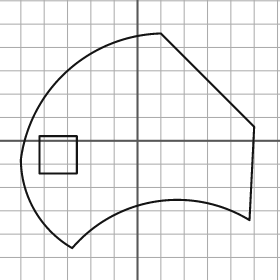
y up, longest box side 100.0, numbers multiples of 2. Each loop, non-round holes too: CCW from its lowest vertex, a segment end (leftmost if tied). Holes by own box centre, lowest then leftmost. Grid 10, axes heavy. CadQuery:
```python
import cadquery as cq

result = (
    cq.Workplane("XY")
    .moveTo(-28.0, -46.0)
    .threePointArc((8.0, -26.0), (48.0, -34.0))
    .lineTo(50.0, 6.0)
    .lineTo(10.0, 46.0)
    .threePointArc((-30.0, 30.0), (-50.0, -8.0))
    .threePointArc((-44.0, -30.0), (-28.0, -46.0))
    .close()
    .moveTo(-42.0, -14.0)
    .lineTo(-26.0, -14.0)
    .lineTo(-26.0, 2.0)
    .lineTo(-42.0, 2.0)
    .close()
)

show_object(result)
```